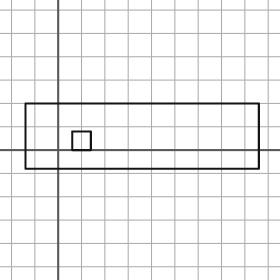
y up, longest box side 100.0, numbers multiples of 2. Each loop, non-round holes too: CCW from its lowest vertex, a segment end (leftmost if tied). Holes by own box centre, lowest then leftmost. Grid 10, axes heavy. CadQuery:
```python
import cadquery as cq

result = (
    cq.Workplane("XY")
    .moveTo(-14.0, -8.0)
    .lineTo(86.0, -8.0)
    .lineTo(86.0, 20.0)
    .lineTo(-14.0, 20.0)
    .close()
    .moveTo(6.0, 0.0)
    .lineTo(14.0, 0.0)
    .lineTo(14.0, 8.0)
    .lineTo(6.0, 8.0)
    .close()
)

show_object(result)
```